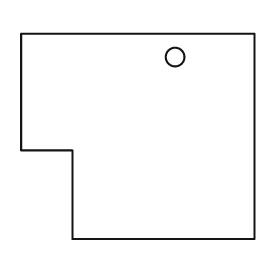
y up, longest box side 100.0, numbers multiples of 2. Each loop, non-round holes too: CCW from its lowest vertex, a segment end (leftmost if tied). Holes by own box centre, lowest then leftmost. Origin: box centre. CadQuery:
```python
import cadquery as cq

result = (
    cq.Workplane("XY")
    .moveTo(-28.0, -44.0)
    .lineTo(50.0, -44.0)
    .lineTo(50.0, 44.0)
    .lineTo(-50.0, 44.0)
    .lineTo(-50.0, -6.0)
    .lineTo(-28.0, -6.0)
    .close()
    .moveTo(16.0, 34.0)
    .circle(4.0)
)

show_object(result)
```